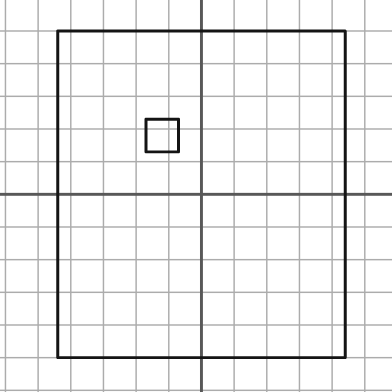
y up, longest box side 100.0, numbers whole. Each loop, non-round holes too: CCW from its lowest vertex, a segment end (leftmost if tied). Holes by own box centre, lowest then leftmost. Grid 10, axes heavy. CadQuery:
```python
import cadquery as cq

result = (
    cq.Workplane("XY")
    .moveTo(-44.0, -50.0)
    .lineTo(44.0, -50.0)
    .lineTo(44.0, 50.0)
    .lineTo(-44.0, 50.0)
    .close()
    .moveTo(-17.0, 13.0)
    .lineTo(-7.0, 13.0)
    .lineTo(-7.0, 23.0)
    .lineTo(-17.0, 23.0)
    .close()
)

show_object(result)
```